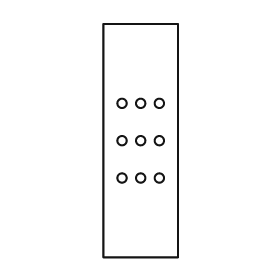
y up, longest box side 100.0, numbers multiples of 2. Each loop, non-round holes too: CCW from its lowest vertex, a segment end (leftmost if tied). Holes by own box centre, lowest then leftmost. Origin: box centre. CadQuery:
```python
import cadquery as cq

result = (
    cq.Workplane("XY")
    .moveTo(-16.0, -50.0)
    .lineTo(16.0, -50.0)
    .lineTo(16.0, 50.0)
    .lineTo(-16.0, 50.0)
    .close()
    .moveTo(-8.0, -16.0)
    .circle(2.0)
    .moveTo(0.0, -16.0)
    .circle(2.0)
    .moveTo(8.0, -16.0)
    .circle(2.0)
    .moveTo(-8.0, 0.0)
    .circle(2.0)
    .moveTo(0.0, 0.0)
    .circle(2.0)
    .moveTo(8.0, 0.0)
    .circle(2.0)
    .moveTo(-8.0, 16.0)
    .circle(2.0)
    .moveTo(0.0, 16.0)
    .circle(2.0)
    .moveTo(8.0, 16.0)
    .circle(2.0)
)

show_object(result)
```